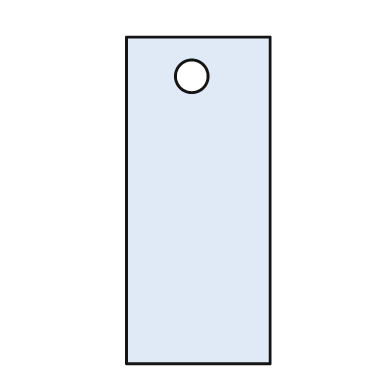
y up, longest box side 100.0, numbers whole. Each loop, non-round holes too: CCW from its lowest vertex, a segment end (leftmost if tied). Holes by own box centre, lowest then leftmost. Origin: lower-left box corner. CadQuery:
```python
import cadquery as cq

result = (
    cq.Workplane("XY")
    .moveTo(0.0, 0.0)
    .lineTo(44.0, 0.0)
    .lineTo(44.0, 100.0)
    .lineTo(0.0, 100.0)
    .close()
    .moveTo(20.0, 88.0)
    .circle(5.0)
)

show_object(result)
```